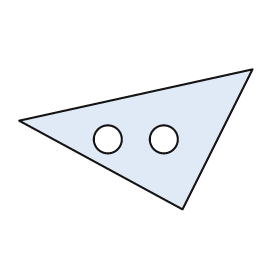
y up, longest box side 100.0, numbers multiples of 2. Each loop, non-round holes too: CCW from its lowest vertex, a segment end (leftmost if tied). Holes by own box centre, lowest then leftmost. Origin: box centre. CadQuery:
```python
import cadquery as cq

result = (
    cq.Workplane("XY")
    .moveTo(20.0, -30.0)
    .lineTo(50.0, 30.0)
    .lineTo(-50.0, 8.0)
    .close()
    .moveTo(-12.0, 0.0)
    .circle(6.0)
    .moveTo(12.0, 0.0)
    .circle(6.0)
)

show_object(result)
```